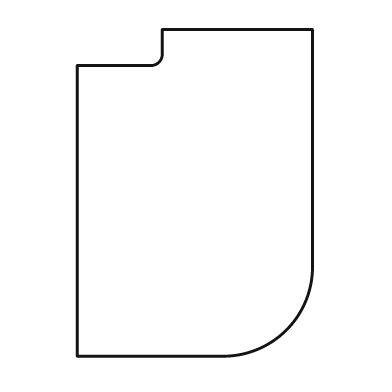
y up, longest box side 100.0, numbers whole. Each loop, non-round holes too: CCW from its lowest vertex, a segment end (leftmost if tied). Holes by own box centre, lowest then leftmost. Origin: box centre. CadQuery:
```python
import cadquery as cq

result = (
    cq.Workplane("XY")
    .moveTo(-36.0, -50.0)
    .lineTo(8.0, -50.0)
    .threePointArc((28.0, -42.0), (36.0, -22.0))
    .lineTo(36.0, 50.0)
    .lineTo(-10.0, 50.0)
    .lineTo(-10.0, 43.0)
    .threePointArc((-11.0, 40.0), (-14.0, 39.0))
    .lineTo(-36.0, 39.0)
    .close()
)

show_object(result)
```